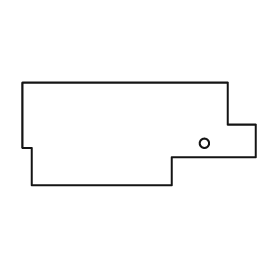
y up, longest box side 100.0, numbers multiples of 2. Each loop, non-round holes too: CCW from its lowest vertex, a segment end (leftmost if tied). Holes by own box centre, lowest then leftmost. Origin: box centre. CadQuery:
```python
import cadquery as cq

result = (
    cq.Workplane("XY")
    .moveTo(-46.0, -22.0)
    .lineTo(14.0, -22.0)
    .lineTo(14.0, -10.0)
    .lineTo(50.0, -10.0)
    .lineTo(50.0, 4.0)
    .lineTo(38.0, 4.0)
    .lineTo(38.0, 22.0)
    .lineTo(-50.0, 22.0)
    .lineTo(-50.0, -6.0)
    .lineTo(-46.0, -6.0)
    .close()
    .moveTo(28.0, -4.0)
    .circle(2.0)
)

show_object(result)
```